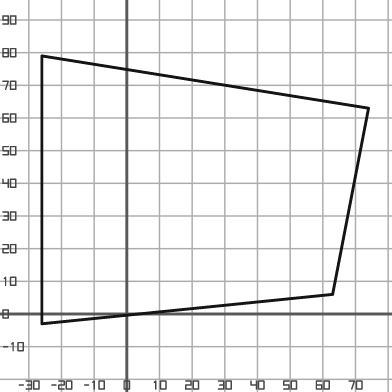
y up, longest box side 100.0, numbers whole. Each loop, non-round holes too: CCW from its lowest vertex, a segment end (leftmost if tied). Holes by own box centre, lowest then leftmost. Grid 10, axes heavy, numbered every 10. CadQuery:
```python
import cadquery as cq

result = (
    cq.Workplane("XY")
    .moveTo(-26.0, -3.0)
    .lineTo(63.0, 6.0)
    .lineTo(74.0, 63.0)
    .lineTo(-26.0, 79.0)
    .close()
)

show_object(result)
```